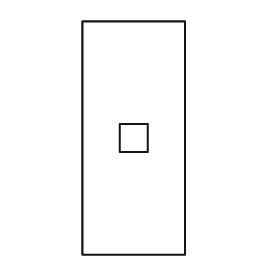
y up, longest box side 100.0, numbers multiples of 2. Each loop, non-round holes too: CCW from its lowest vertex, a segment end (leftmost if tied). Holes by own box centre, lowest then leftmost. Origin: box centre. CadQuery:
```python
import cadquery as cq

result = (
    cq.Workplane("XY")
    .moveTo(-22.0, -50.0)
    .lineTo(22.0, -50.0)
    .lineTo(22.0, 50.0)
    .lineTo(-22.0, 50.0)
    .close()
    .moveTo(-6.0, -6.0)
    .lineTo(6.0, -6.0)
    .lineTo(6.0, 6.0)
    .lineTo(-6.0, 6.0)
    .close()
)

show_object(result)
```